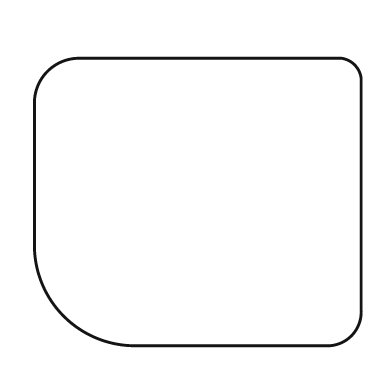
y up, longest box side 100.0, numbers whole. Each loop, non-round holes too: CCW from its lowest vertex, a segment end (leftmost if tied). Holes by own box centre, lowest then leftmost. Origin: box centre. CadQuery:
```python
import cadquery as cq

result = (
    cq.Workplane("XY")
    .moveTo(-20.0, -44.0)
    .lineTo(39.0, -44.0)
    .threePointArc((47.0, -41.0), (50.0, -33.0))
    .lineTo(50.0, 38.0)
    .threePointArc((48.0, 42.0), (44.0, 44.0))
    .lineTo(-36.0, 44.0)
    .threePointArc((-46.0, 40.0), (-50.0, 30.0))
    .lineTo(-50.0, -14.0)
    .threePointArc((-41.0, -35.0), (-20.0, -44.0))
    .close()
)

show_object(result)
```